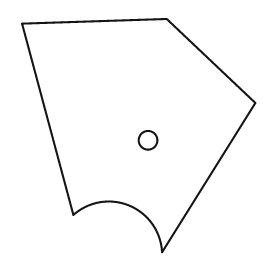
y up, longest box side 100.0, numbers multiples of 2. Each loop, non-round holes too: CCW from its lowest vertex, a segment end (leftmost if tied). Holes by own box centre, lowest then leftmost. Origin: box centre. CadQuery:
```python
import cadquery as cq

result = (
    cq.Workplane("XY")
    .moveTo(10.0, -50.0)
    .lineTo(50.0, 14.0)
    .lineTo(12.0, 50.0)
    .lineTo(-50.0, 48.0)
    .lineTo(-28.0, -34.0)
    .threePointArc((-4.0, -30.0), (10.0, -50.0))
    .close()
    .moveTo(4.0, -2.0)
    .circle(4.0)
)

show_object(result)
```